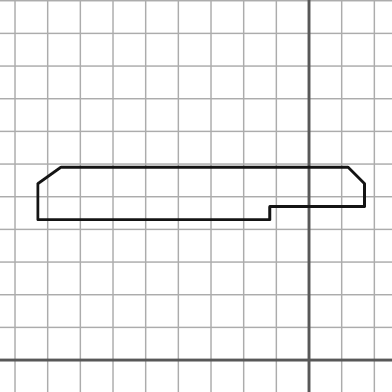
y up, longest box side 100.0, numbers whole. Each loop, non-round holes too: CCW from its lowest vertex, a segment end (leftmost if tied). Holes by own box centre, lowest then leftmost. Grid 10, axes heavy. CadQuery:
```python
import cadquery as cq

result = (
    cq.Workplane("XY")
    .moveTo(-83.0, 43.0)
    .lineTo(-12.0, 43.0)
    .lineTo(-12.0, 47.0)
    .lineTo(17.0, 47.0)
    .lineTo(17.0, 54.0)
    .lineTo(12.0, 59.0)
    .lineTo(-76.0, 59.0)
    .lineTo(-83.0, 54.0)
    .close()
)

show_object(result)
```